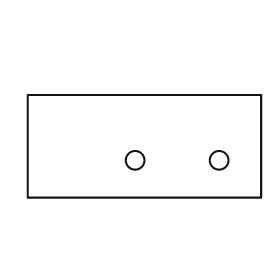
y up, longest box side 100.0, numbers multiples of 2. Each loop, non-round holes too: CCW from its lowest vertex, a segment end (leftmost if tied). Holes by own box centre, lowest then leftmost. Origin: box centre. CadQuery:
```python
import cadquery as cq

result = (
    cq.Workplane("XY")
    .moveTo(-50.0, -22.0)
    .lineTo(50.0, -22.0)
    .lineTo(50.0, 22.0)
    .lineTo(-50.0, 22.0)
    .close()
    .moveTo(-4.0, -6.0)
    .circle(4.0)
    .moveTo(32.0, -6.0)
    .circle(4.0)
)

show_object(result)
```